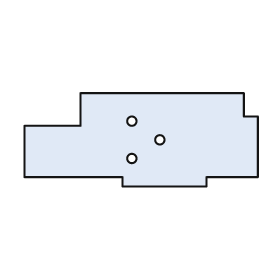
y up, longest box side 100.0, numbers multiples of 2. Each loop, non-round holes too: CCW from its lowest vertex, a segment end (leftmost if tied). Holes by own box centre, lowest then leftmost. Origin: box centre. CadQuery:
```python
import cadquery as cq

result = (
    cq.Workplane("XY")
    .moveTo(-8.0, -20.0)
    .lineTo(28.0, -20.0)
    .lineTo(28.0, -16.0)
    .lineTo(50.0, -16.0)
    .lineTo(50.0, 10.0)
    .lineTo(44.0, 10.0)
    .lineTo(44.0, 20.0)
    .lineTo(-26.0, 20.0)
    .lineTo(-26.0, 6.0)
    .lineTo(-50.0, 6.0)
    .lineTo(-50.0, -16.0)
    .lineTo(-8.0, -16.0)
    .close()
    .moveTo(-4.0, -8.0)
    .circle(2.0)
    .moveTo(8.0, 0.0)
    .circle(2.0)
    .moveTo(-4.0, 8.0)
    .circle(2.0)
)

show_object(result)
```